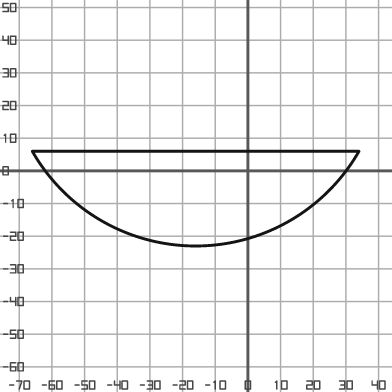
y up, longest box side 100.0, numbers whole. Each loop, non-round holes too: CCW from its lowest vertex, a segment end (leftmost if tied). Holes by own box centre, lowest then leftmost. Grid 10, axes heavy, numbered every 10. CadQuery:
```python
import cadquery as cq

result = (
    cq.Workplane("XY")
    .moveTo(-66.0, 6.0)
    .threePointArc((-16.0, -23.0), (34.0, 6.0))
    .close()
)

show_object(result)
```